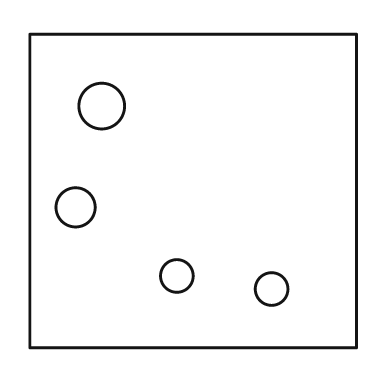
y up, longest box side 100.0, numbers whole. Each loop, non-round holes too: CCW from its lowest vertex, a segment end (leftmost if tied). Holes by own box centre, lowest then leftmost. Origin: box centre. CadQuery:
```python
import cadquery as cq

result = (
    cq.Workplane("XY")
    .moveTo(-50.0, -48.0)
    .lineTo(50.0, -48.0)
    .lineTo(50.0, 48.0)
    .lineTo(-50.0, 48.0)
    .close()
    .moveTo(24.0, -30.0)
    .circle(5.0)
    .moveTo(-5.0, -26.0)
    .circle(5.0)
    .moveTo(-36.0, -5.0)
    .circle(6.0)
    .moveTo(-28.0, 26.0)
    .circle(7.0)
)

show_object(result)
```